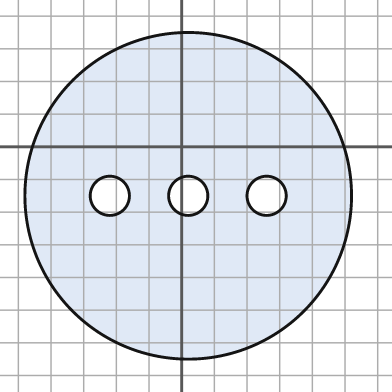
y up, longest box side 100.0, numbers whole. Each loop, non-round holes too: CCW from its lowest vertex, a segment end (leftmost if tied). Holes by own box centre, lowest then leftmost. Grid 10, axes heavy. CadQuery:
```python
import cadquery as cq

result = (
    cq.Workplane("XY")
    .moveTo(2.0, -15.0)
    .circle(50.0)
    .moveTo(-22.0, -15.0)
    .circle(6.0)
    .moveTo(2.0, -15.0)
    .circle(6.0)
    .moveTo(26.0, -15.0)
    .circle(6.0)
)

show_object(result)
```